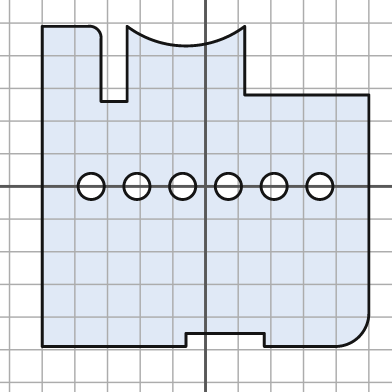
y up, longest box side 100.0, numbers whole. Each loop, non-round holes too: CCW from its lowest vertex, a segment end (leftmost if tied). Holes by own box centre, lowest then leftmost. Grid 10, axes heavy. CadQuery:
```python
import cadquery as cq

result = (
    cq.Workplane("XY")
    .moveTo(-50.0, -49.0)
    .lineTo(-6.0, -49.0)
    .lineTo(-6.0, -45.0)
    .lineTo(18.0, -45.0)
    .lineTo(18.0, -49.0)
    .lineTo(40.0, -49.0)
    .threePointArc((47.0, -46.0), (50.0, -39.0))
    .lineTo(50.0, 28.0)
    .lineTo(12.0, 28.0)
    .lineTo(12.0, 49.0)
    .threePointArc((-6.0, 43.0), (-24.0, 49.0))
    .lineTo(-24.0, 26.0)
    .lineTo(-32.0, 26.0)
    .lineTo(-32.0, 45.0)
    .threePointArc((-33.0, 48.0), (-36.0, 49.0))
    .lineTo(-50.0, 49.0)
    .close()
    .moveTo(-35.0, 0.0)
    .circle(4.0)
    .moveTo(-21.0, 0.0)
    .circle(4.0)
    .moveTo(-7.0, 0.0)
    .circle(4.0)
    .moveTo(7.0, 0.0)
    .circle(4.0)
    .moveTo(21.0, 0.0)
    .circle(4.0)
    .moveTo(35.0, 0.0)
    .circle(4.0)
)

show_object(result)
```